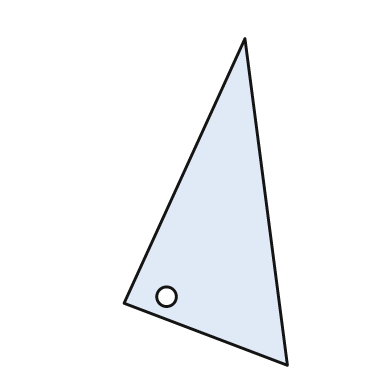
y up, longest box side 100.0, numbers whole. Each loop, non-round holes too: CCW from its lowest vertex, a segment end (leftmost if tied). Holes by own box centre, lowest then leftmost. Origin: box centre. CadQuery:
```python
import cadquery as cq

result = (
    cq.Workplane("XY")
    .moveTo(25.0, -50.0)
    .lineTo(12.0, 50.0)
    .lineTo(-25.0, -31.0)
    .close()
    .moveTo(-12.0, -29.0)
    .circle(3.0)
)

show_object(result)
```